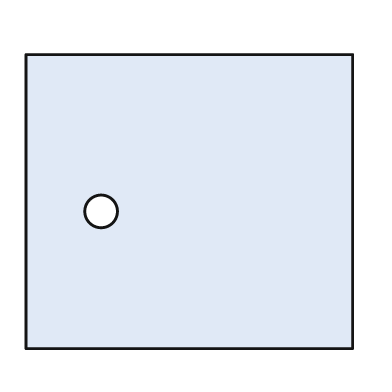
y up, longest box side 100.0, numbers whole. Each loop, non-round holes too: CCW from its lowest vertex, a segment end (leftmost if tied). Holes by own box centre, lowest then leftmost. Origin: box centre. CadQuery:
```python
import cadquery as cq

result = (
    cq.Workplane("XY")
    .moveTo(-50.0, -45.0)
    .lineTo(50.0, -45.0)
    .lineTo(50.0, 45.0)
    .lineTo(-50.0, 45.0)
    .close()
    .moveTo(-27.0, -3.0)
    .circle(5.0)
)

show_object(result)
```